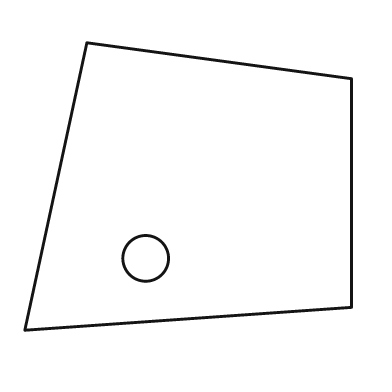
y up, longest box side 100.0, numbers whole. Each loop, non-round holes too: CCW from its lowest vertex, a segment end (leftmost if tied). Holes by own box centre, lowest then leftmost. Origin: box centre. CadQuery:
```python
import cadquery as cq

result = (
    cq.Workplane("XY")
    .moveTo(-50.0, -44.0)
    .lineTo(50.0, -37.0)
    .lineTo(50.0, 33.0)
    .lineTo(-31.0, 44.0)
    .close()
    .moveTo(-13.0, -22.0)
    .circle(7.0)
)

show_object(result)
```